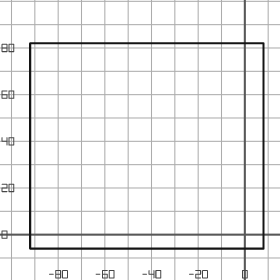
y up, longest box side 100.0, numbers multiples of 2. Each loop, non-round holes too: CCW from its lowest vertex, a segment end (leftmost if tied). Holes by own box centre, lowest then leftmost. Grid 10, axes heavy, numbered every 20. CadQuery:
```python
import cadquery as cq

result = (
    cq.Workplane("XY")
    .moveTo(-92.0, -6.0)
    .lineTo(8.0, -6.0)
    .lineTo(8.0, 82.0)
    .lineTo(-92.0, 82.0)
    .close()
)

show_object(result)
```